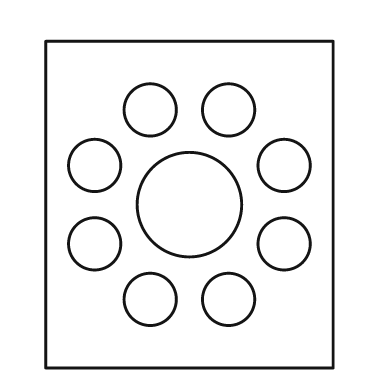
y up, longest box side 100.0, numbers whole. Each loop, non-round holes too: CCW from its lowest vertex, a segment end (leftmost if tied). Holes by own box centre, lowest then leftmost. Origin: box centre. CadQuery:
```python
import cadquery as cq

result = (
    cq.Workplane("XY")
    .moveTo(-44.0, -50.0)
    .lineTo(44.0, -50.0)
    .lineTo(44.0, 50.0)
    .lineTo(-44.0, 50.0)
    .close()
    .moveTo(-12.0, -29.0)
    .circle(8.0)
    .moveTo(12.0, -29.0)
    .circle(8.0)
    .moveTo(-29.0, -12.0)
    .circle(8.0)
    .moveTo(29.0, -12.0)
    .circle(8.0)
    .moveTo(0.0, 0.0)
    .circle(16.0)
    .moveTo(-29.0, 12.0)
    .circle(8.0)
    .moveTo(29.0, 12.0)
    .circle(8.0)
    .moveTo(-12.0, 29.0)
    .circle(8.0)
    .moveTo(12.0, 29.0)
    .circle(8.0)
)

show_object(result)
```